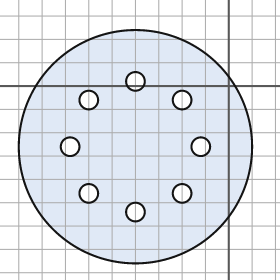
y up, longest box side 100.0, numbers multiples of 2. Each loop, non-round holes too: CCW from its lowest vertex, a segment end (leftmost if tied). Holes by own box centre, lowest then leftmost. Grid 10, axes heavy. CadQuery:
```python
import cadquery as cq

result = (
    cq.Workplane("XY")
    .moveTo(-40.0, -26.0)
    .circle(50.0)
    .moveTo(-40.0, -54.0)
    .circle(4.0)
    .moveTo(-60.0, -46.0)
    .circle(4.0)
    .moveTo(-20.0, -46.0)
    .circle(4.0)
    .moveTo(-68.0, -26.0)
    .circle(4.0)
    .moveTo(-12.0, -26.0)
    .circle(4.0)
    .moveTo(-60.0, -6.0)
    .circle(4.0)
    .moveTo(-20.0, -6.0)
    .circle(4.0)
    .moveTo(-40.0, 2.0)
    .circle(4.0)
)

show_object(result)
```